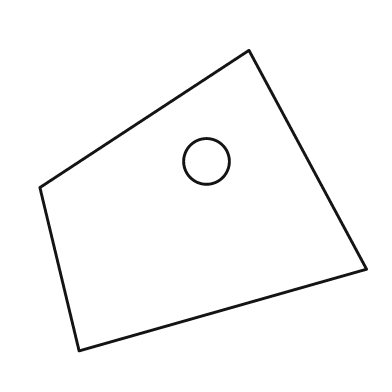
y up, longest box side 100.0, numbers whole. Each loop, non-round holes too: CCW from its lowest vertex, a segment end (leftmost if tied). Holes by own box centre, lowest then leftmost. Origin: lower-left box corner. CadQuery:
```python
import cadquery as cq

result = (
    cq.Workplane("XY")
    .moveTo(12.0, 0.0)
    .lineTo(100.0, 25.0)
    .lineTo(64.0, 92.0)
    .lineTo(0.0, 50.0)
    .close()
    .moveTo(51.0, 58.0)
    .circle(7.0)
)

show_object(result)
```